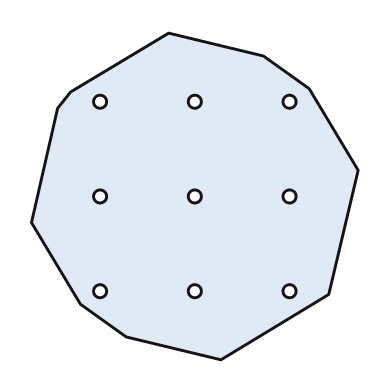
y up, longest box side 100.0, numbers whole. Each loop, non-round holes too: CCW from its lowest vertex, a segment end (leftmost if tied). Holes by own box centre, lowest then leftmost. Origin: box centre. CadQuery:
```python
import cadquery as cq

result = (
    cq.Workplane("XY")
    .moveTo(8.0, -50.0)
    .lineTo(41.0, -30.0)
    .lineTo(50.0, 8.0)
    .lineTo(35.0, 33.0)
    .lineTo(21.0, 43.0)
    .lineTo(-8.0, 50.0)
    .lineTo(-38.0, 32.0)
    .lineTo(-42.0, 27.0)
    .lineTo(-50.0, -8.0)
    .lineTo(-35.0, -33.0)
    .lineTo(-21.0, -43.0)
    .close()
    .moveTo(-29.0, -29.0)
    .circle(2.0)
    .moveTo(0.0, -29.0)
    .circle(2.0)
    .moveTo(29.0, -29.0)
    .circle(2.0)
    .moveTo(-29.0, 0.0)
    .circle(2.0)
    .moveTo(0.0, 0.0)
    .circle(2.0)
    .moveTo(29.0, 0.0)
    .circle(2.0)
    .moveTo(-29.0, 29.0)
    .circle(2.0)
    .moveTo(0.0, 29.0)
    .circle(2.0)
    .moveTo(29.0, 29.0)
    .circle(2.0)
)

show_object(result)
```